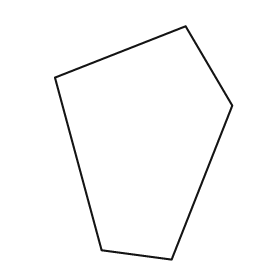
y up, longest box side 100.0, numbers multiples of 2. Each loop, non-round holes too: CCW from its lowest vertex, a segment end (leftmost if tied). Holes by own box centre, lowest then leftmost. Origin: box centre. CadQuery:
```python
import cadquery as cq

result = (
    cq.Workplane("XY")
    .moveTo(12.0, -50.0)
    .lineTo(38.0, 16.0)
    .lineTo(18.0, 50.0)
    .lineTo(-38.0, 28.0)
    .lineTo(-18.0, -46.0)
    .close()
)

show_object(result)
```